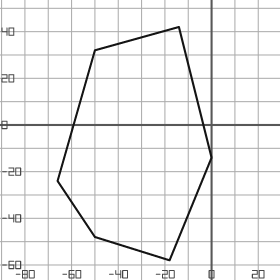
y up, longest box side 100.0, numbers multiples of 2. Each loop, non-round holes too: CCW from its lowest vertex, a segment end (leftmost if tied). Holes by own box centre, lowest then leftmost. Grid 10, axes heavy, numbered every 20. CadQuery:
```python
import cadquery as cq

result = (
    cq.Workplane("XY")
    .moveTo(-18.0, -58.0)
    .lineTo(0.0, -14.0)
    .lineTo(-14.0, 42.0)
    .lineTo(-50.0, 32.0)
    .lineTo(-66.0, -24.0)
    .lineTo(-50.0, -48.0)
    .close()
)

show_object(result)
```